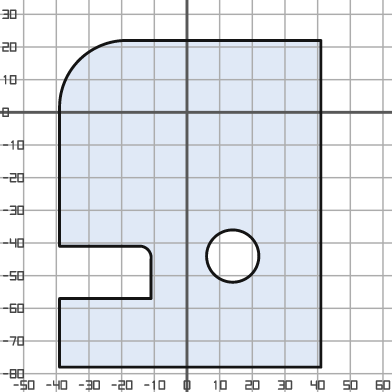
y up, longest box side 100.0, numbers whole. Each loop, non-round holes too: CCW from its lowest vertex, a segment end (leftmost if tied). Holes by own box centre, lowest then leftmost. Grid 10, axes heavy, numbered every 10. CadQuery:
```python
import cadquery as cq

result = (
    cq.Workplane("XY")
    .moveTo(-39.0, -78.0)
    .lineTo(41.0, -78.0)
    .lineTo(41.0, 22.0)
    .lineTo(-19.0, 22.0)
    .threePointArc((-33.0, 16.0), (-39.0, 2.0))
    .lineTo(-39.0, -41.0)
    .lineTo(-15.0, -41.0)
    .threePointArc((-12.0, -42.0), (-11.0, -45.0))
    .lineTo(-11.0, -57.0)
    .lineTo(-39.0, -57.0)
    .close()
    .moveTo(14.0, -44.0)
    .circle(8.0)
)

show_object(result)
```